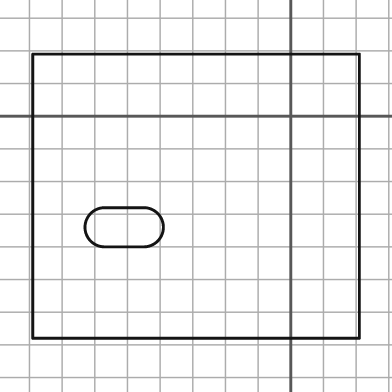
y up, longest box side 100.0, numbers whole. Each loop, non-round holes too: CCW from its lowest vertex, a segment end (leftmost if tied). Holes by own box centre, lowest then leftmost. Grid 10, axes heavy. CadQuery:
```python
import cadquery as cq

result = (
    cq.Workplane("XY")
    .moveTo(-79.0, -68.0)
    .lineTo(21.0, -68.0)
    .lineTo(21.0, 19.0)
    .lineTo(-79.0, 19.0)
    .close()
    .moveTo(-57.0, -40.0)
    .lineTo(-45.0, -40.0)
    .threePointArc((-39.0, -34.0), (-45.0, -28.0))
    .lineTo(-57.0, -28.0)
    .threePointArc((-63.0, -34.0), (-57.0, -40.0))
    .close()
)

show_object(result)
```